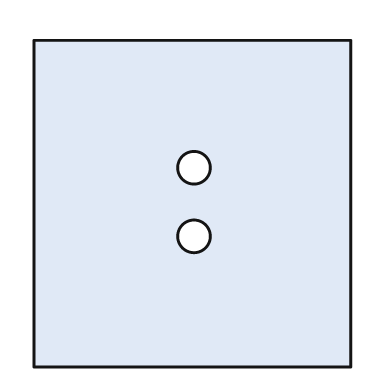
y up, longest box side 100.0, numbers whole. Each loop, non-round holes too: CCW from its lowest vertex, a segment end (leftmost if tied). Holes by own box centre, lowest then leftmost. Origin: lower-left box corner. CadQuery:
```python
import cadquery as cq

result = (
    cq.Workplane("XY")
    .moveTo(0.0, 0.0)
    .lineTo(97.0, 0.0)
    .lineTo(97.0, 100.0)
    .lineTo(0.0, 100.0)
    .close()
    .moveTo(49.0, 40.0)
    .circle(5.0)
    .moveTo(49.0, 61.0)
    .circle(5.0)
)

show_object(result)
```